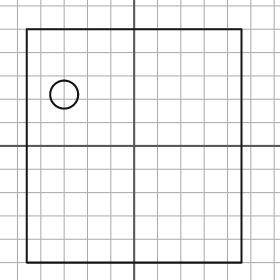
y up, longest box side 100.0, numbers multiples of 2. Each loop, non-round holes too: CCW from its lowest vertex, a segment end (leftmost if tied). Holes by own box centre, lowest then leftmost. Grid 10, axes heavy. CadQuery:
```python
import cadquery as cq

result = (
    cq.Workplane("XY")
    .moveTo(-46.0, -50.0)
    .lineTo(46.0, -50.0)
    .lineTo(46.0, 50.0)
    .lineTo(-46.0, 50.0)
    .close()
    .moveTo(-30.0, 22.0)
    .circle(6.0)
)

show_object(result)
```